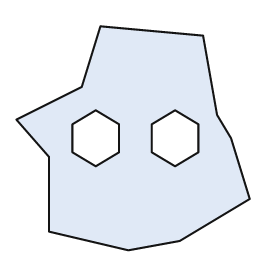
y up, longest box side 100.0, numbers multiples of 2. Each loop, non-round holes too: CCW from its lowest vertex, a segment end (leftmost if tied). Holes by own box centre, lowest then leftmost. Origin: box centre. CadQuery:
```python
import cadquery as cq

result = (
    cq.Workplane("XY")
    .moveTo(-2.0, -48.0)
    .lineTo(20.0, -44.0)
    .lineTo(50.0, -26.0)
    .lineTo(42.0, 0.0)
    .lineTo(36.0, 10.0)
    .lineTo(30.0, 44.0)
    .lineTo(-14.0, 48.0)
    .lineTo(-22.0, 22.0)
    .lineTo(-50.0, 8.0)
    .lineTo(-36.0, -8.0)
    .lineTo(-36.0, -40.0)
    .close()
    .moveTo(-16.0, -12.0)
    .lineTo(-6.0, -6.0)
    .lineTo(-6.0, 6.0)
    .lineTo(-16.0, 12.0)
    .lineTo(-26.0, 6.0)
    .lineTo(-26.0, -6.0)
    .close()
    .moveTo(18.0, -12.0)
    .lineTo(28.0, -6.0)
    .lineTo(28.0, 6.0)
    .lineTo(18.0, 12.0)
    .lineTo(8.0, 6.0)
    .lineTo(8.0, -6.0)
    .close()
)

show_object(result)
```